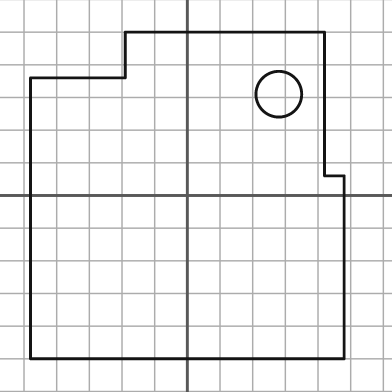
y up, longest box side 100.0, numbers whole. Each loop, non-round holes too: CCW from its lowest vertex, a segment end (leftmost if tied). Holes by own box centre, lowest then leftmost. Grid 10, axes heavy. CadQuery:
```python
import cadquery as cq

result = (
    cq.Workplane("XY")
    .moveTo(-48.0, -50.0)
    .lineTo(48.0, -50.0)
    .lineTo(48.0, 6.0)
    .lineTo(42.0, 6.0)
    .lineTo(42.0, 50.0)
    .lineTo(-19.0, 50.0)
    .lineTo(-19.0, 36.0)
    .lineTo(-48.0, 36.0)
    .close()
    .moveTo(28.0, 31.0)
    .circle(7.0)
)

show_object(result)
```